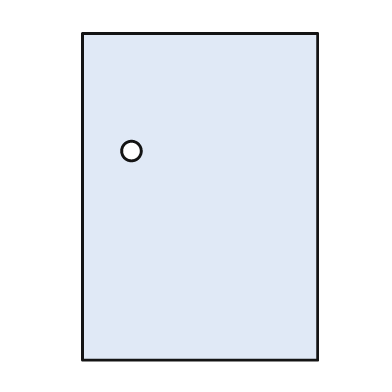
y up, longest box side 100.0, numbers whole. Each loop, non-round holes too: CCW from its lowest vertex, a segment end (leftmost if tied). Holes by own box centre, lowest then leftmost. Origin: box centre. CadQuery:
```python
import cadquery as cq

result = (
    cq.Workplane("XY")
    .moveTo(-36.0, -50.0)
    .lineTo(36.0, -50.0)
    .lineTo(36.0, 50.0)
    .lineTo(-36.0, 50.0)
    .close()
    .moveTo(-21.0, 14.0)
    .circle(3.0)
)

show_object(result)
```